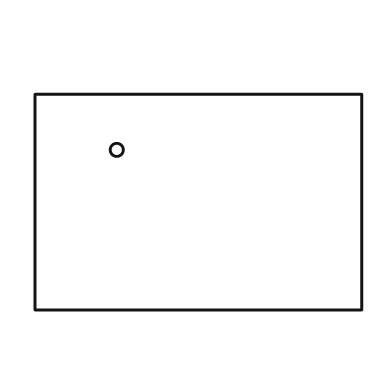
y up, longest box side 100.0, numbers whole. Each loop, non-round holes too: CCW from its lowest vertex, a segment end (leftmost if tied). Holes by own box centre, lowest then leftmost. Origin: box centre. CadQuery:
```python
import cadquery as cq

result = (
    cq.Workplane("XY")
    .moveTo(-50.0, -33.0)
    .lineTo(50.0, -33.0)
    .lineTo(50.0, 33.0)
    .lineTo(-50.0, 33.0)
    .close()
    .moveTo(-25.0, 16.0)
    .circle(2.0)
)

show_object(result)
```